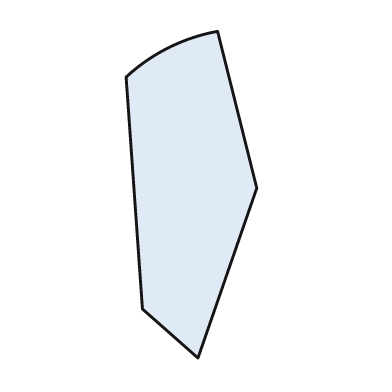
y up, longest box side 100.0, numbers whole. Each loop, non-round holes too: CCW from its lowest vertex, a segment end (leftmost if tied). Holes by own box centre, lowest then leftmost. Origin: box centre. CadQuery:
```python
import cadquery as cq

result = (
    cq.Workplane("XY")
    .moveTo(2.0, -50.0)
    .lineTo(20.0, 2.0)
    .lineTo(8.0, 50.0)
    .threePointArc((-7.0, 45.0), (-20.0, 36.0))
    .lineTo(-15.0, -35.0)
    .close()
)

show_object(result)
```